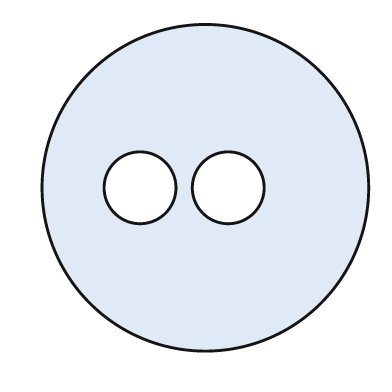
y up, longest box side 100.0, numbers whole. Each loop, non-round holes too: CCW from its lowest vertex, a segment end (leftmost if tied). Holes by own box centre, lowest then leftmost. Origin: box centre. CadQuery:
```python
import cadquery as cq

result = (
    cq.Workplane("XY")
    .moveTo(0.0, 0.0)
    .circle(50.0)
    .moveTo(-20.0, 0.0)
    .circle(11.0)
    .moveTo(7.0, 0.0)
    .circle(11.0)
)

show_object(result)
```